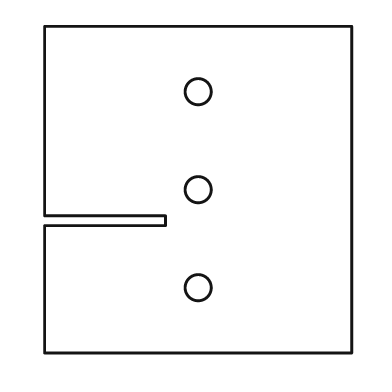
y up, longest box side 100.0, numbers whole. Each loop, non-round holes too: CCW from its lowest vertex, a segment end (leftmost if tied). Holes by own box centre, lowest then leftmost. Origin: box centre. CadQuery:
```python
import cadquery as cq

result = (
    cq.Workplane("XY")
    .moveTo(-47.0, -50.0)
    .lineTo(47.0, -50.0)
    .lineTo(47.0, 50.0)
    .lineTo(-47.0, 50.0)
    .lineTo(-47.0, -8.0)
    .lineTo(-10.0, -8.0)
    .lineTo(-10.0, -11.0)
    .lineTo(-47.0, -11.0)
    .close()
    .moveTo(0.0, -30.0)
    .circle(4.0)
    .moveTo(0.0, 0.0)
    .circle(4.0)
    .moveTo(0.0, 30.0)
    .circle(4.0)
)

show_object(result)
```